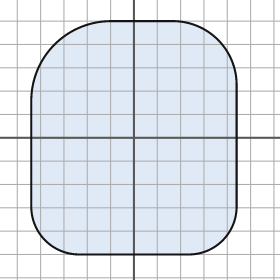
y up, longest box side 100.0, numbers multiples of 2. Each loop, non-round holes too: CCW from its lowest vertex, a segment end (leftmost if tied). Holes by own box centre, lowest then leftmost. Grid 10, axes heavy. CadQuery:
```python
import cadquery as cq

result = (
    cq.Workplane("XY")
    .moveTo(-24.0, -50.0)
    .lineTo(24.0, -50.0)
    .threePointArc((38.0, -44.0), (44.0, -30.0))
    .lineTo(44.0, 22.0)
    .threePointArc((36.0, 42.0), (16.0, 50.0))
    .lineTo(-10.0, 50.0)
    .threePointArc((-34.0, 40.0), (-44.0, 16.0))
    .lineTo(-44.0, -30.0)
    .threePointArc((-38.0, -44.0), (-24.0, -50.0))
    .close()
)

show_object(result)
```